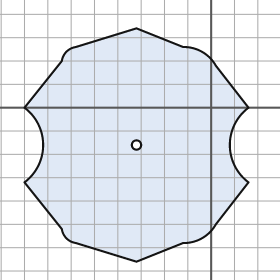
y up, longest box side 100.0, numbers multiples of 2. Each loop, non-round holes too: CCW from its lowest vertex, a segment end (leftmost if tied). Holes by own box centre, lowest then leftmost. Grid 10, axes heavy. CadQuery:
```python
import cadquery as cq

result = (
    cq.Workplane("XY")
    .moveTo(-32.0, -66.0)
    .lineTo(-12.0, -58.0)
    .threePointArc((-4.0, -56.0), (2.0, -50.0))
    .lineTo(16.0, -32.0)
    .threePointArc((8.0, -16.0), (16.0, 0.0))
    .lineTo(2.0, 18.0)
    .threePointArc((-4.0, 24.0), (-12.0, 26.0))
    .lineTo(-32.0, 34.0)
    .lineTo(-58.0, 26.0)
    .threePointArc((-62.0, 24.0), (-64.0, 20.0))
    .lineTo(-80.0, 0.0)
    .threePointArc((-72.0, -16.0), (-80.0, -32.0))
    .lineTo(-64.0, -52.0)
    .threePointArc((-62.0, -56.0), (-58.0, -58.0))
    .close()
    .moveTo(-32.0, -16.0)
    .circle(2.0)
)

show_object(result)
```